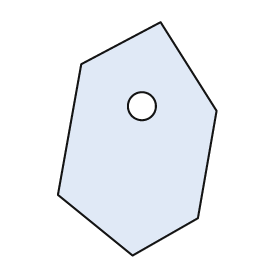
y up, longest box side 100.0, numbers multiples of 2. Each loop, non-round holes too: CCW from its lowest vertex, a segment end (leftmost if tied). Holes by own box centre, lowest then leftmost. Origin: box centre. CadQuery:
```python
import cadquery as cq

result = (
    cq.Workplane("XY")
    .moveTo(-2.0, -50.0)
    .lineTo(26.0, -34.0)
    .lineTo(34.0, 12.0)
    .lineTo(10.0, 50.0)
    .lineTo(-24.0, 32.0)
    .lineTo(-34.0, -24.0)
    .close()
    .moveTo(2.0, 14.0)
    .circle(6.0)
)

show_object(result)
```